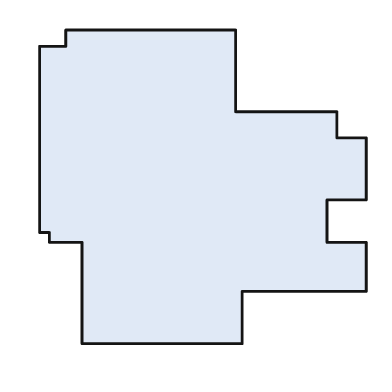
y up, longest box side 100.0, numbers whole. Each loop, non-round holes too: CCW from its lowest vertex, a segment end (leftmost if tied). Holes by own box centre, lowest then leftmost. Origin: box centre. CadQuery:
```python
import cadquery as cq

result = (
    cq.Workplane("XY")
    .moveTo(-37.0, -48.0)
    .lineTo(12.0, -48.0)
    .lineTo(12.0, -32.0)
    .lineTo(50.0, -32.0)
    .lineTo(50.0, -17.0)
    .lineTo(38.0, -17.0)
    .lineTo(38.0, -4.0)
    .lineTo(50.0, -4.0)
    .lineTo(50.0, 15.0)
    .lineTo(41.0, 15.0)
    .lineTo(41.0, 23.0)
    .lineTo(10.0, 23.0)
    .lineTo(10.0, 48.0)
    .lineTo(-42.0, 48.0)
    .lineTo(-42.0, 43.0)
    .lineTo(-50.0, 43.0)
    .lineTo(-50.0, -14.0)
    .lineTo(-47.0, -14.0)
    .lineTo(-47.0, -17.0)
    .lineTo(-37.0, -17.0)
    .close()
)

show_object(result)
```